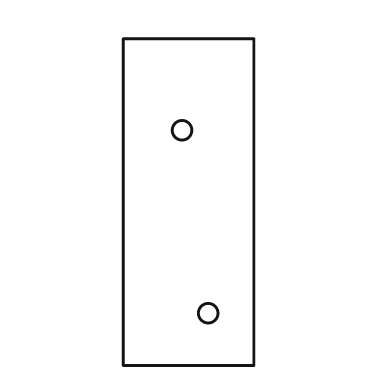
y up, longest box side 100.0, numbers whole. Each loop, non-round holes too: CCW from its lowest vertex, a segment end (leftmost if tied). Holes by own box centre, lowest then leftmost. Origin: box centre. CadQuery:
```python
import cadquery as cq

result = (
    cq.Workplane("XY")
    .moveTo(-20.0, -50.0)
    .lineTo(20.0, -50.0)
    .lineTo(20.0, 50.0)
    .lineTo(-20.0, 50.0)
    .close()
    .moveTo(6.0, -34.0)
    .circle(3.0)
    .moveTo(-2.0, 22.0)
    .circle(3.0)
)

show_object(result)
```